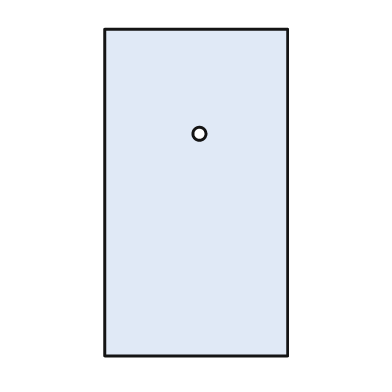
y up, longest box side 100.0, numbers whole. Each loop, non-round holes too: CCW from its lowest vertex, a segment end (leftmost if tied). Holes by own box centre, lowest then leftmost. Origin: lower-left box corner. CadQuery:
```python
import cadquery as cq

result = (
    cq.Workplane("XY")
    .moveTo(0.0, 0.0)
    .lineTo(56.0, 0.0)
    .lineTo(56.0, 100.0)
    .lineTo(0.0, 100.0)
    .close()
    .moveTo(29.0, 68.0)
    .circle(2.0)
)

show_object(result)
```